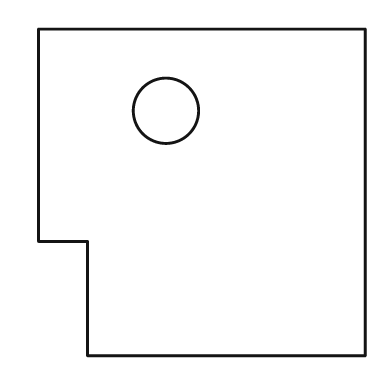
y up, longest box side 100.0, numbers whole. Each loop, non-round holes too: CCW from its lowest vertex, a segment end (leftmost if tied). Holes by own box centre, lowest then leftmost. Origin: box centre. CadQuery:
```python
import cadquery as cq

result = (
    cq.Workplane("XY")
    .moveTo(-35.0, -50.0)
    .lineTo(50.0, -50.0)
    .lineTo(50.0, 50.0)
    .lineTo(-50.0, 50.0)
    .lineTo(-50.0, -15.0)
    .lineTo(-35.0, -15.0)
    .close()
    .moveTo(-11.0, 25.0)
    .circle(10.0)
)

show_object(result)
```